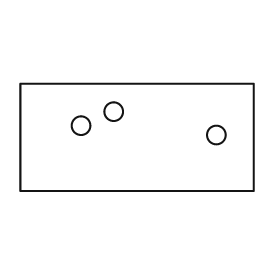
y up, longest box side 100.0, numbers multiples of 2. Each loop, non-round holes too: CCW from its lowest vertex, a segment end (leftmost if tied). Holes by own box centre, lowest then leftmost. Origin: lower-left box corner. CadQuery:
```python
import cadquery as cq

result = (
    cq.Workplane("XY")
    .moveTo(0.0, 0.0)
    .lineTo(100.0, 0.0)
    .lineTo(100.0, 46.0)
    .lineTo(0.0, 46.0)
    .close()
    .moveTo(84.0, 24.0)
    .circle(4.0)
    .moveTo(26.0, 28.0)
    .circle(4.0)
    .moveTo(40.0, 34.0)
    .circle(4.0)
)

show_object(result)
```